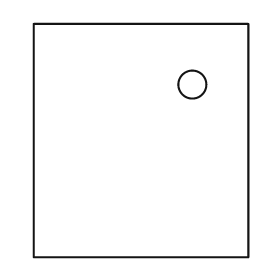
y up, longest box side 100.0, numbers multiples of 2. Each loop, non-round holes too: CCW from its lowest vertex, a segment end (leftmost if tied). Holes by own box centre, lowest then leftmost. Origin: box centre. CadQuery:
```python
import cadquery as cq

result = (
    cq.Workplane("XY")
    .moveTo(-46.0, -50.0)
    .lineTo(46.0, -50.0)
    .lineTo(46.0, 50.0)
    .lineTo(-46.0, 50.0)
    .close()
    .moveTo(22.0, 24.0)
    .circle(6.0)
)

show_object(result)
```